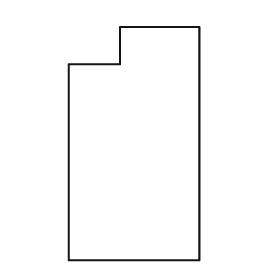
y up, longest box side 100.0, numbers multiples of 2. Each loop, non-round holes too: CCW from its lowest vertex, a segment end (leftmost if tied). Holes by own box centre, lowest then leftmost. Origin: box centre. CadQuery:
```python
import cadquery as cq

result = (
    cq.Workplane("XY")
    .moveTo(-28.0, -50.0)
    .lineTo(28.0, -50.0)
    .lineTo(28.0, 50.0)
    .lineTo(-6.0, 50.0)
    .lineTo(-6.0, 34.0)
    .lineTo(-28.0, 34.0)
    .close()
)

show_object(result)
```